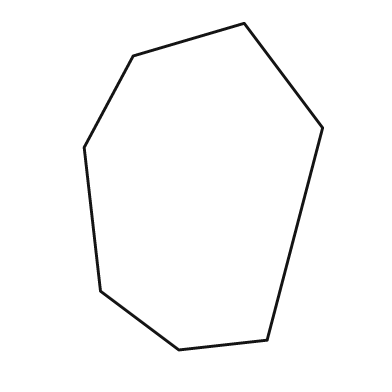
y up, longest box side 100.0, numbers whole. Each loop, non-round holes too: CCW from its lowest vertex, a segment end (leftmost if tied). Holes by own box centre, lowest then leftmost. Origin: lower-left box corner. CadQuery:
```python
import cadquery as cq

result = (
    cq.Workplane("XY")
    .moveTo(29.0, 0.0)
    .lineTo(56.0, 3.0)
    .lineTo(73.0, 68.0)
    .lineTo(49.0, 100.0)
    .lineTo(15.0, 90.0)
    .lineTo(0.0, 62.0)
    .lineTo(5.0, 18.0)
    .close()
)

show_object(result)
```